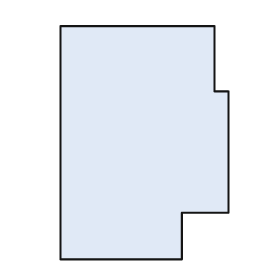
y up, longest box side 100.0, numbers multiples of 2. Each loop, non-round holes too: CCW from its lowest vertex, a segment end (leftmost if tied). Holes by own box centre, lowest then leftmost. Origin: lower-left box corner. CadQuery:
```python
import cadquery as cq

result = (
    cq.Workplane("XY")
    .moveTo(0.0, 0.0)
    .lineTo(52.0, 0.0)
    .lineTo(52.0, 20.0)
    .lineTo(72.0, 20.0)
    .lineTo(72.0, 72.0)
    .lineTo(66.0, 72.0)
    .lineTo(66.0, 100.0)
    .lineTo(0.0, 100.0)
    .close()
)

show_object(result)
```